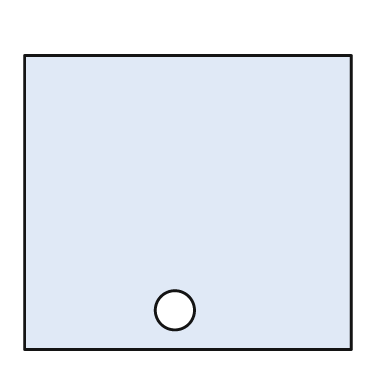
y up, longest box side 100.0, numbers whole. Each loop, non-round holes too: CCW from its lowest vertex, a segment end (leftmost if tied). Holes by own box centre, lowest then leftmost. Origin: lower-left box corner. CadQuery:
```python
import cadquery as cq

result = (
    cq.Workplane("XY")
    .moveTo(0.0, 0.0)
    .lineTo(100.0, 0.0)
    .lineTo(100.0, 90.0)
    .lineTo(0.0, 90.0)
    .close()
    .moveTo(46.0, 12.0)
    .circle(6.0)
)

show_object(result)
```